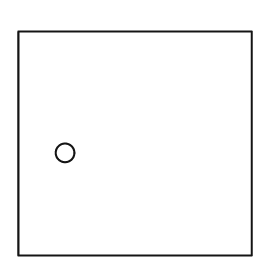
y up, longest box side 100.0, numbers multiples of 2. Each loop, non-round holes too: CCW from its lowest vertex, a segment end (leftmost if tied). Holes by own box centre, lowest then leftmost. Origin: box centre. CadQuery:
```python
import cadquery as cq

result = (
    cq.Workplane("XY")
    .moveTo(-50.0, -48.0)
    .lineTo(50.0, -48.0)
    .lineTo(50.0, 48.0)
    .lineTo(-50.0, 48.0)
    .close()
    .moveTo(-30.0, -4.0)
    .circle(4.0)
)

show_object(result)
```